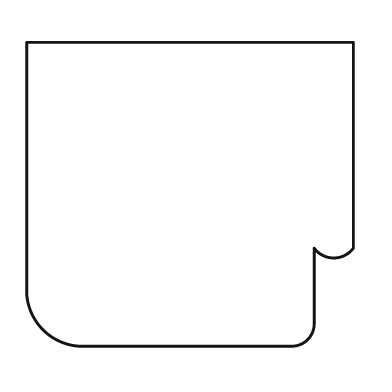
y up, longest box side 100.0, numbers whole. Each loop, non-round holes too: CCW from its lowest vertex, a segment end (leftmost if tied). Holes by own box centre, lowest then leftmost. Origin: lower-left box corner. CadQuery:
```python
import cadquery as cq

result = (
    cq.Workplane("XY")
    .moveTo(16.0, 0.0)
    .lineTo(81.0, 0.0)
    .threePointArc((86.0, 2.0), (88.0, 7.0))
    .lineTo(88.0, 30.0)
    .threePointArc((94.0, 27.0), (100.0, 30.0))
    .lineTo(100.0, 93.0)
    .lineTo(0.0, 93.0)
    .lineTo(0.0, 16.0)
    .threePointArc((5.0, 5.0), (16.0, 0.0))
    .close()
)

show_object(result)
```